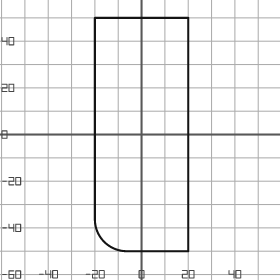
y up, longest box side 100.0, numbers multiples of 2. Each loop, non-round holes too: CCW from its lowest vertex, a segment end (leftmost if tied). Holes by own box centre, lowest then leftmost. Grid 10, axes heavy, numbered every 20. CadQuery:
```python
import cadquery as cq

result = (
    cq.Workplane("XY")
    .moveTo(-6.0, -50.0)
    .lineTo(20.0, -50.0)
    .lineTo(20.0, 50.0)
    .lineTo(-20.0, 50.0)
    .lineTo(-20.0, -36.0)
    .threePointArc((-16.0, -46.0), (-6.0, -50.0))
    .close()
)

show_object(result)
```